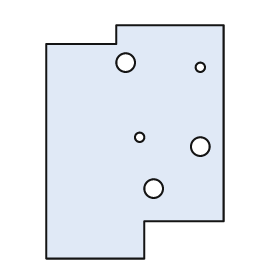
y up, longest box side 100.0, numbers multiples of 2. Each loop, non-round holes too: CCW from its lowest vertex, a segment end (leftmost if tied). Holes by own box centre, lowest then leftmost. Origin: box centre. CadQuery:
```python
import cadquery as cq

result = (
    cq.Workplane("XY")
    .moveTo(-38.0, -50.0)
    .lineTo(4.0, -50.0)
    .lineTo(4.0, -34.0)
    .lineTo(38.0, -34.0)
    .lineTo(38.0, 50.0)
    .lineTo(-8.0, 50.0)
    .lineTo(-8.0, 42.0)
    .lineTo(-38.0, 42.0)
    .close()
    .moveTo(8.0, -20.0)
    .circle(4.0)
    .moveTo(28.0, -2.0)
    .circle(4.0)
    .moveTo(2.0, 2.0)
    .circle(2.0)
    .moveTo(28.0, 32.0)
    .circle(2.0)
    .moveTo(-4.0, 34.0)
    .circle(4.0)
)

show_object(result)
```